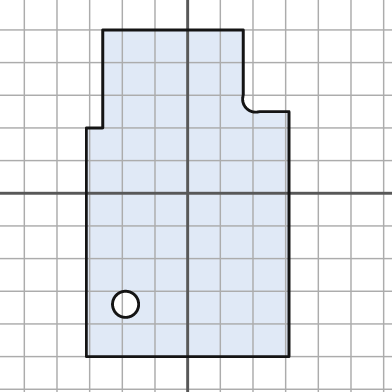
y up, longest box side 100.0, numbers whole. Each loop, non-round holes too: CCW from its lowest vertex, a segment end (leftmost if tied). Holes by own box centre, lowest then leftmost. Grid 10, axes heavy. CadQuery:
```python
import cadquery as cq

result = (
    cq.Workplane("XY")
    .moveTo(-31.0, -50.0)
    .lineTo(31.0, -50.0)
    .lineTo(31.0, 25.0)
    .lineTo(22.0, 25.0)
    .threePointArc((18.0, 26.0), (17.0, 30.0))
    .lineTo(17.0, 50.0)
    .lineTo(-26.0, 50.0)
    .lineTo(-26.0, 20.0)
    .lineTo(-31.0, 20.0)
    .close()
    .moveTo(-19.0, -34.0)
    .circle(4.0)
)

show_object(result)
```